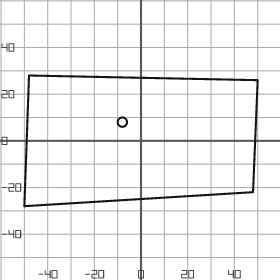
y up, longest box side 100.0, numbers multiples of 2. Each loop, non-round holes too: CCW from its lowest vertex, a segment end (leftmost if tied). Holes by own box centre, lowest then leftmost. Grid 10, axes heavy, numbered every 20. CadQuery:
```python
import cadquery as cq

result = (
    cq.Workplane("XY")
    .moveTo(-50.0, -28.0)
    .lineTo(48.0, -22.0)
    .lineTo(50.0, 26.0)
    .lineTo(-48.0, 28.0)
    .close()
    .moveTo(-8.0, 8.0)
    .circle(2.0)
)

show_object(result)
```